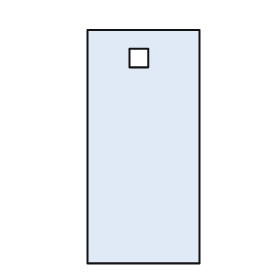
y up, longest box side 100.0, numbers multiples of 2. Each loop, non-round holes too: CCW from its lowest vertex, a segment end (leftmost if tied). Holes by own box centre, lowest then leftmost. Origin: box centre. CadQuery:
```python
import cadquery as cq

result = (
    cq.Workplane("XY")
    .moveTo(-24.0, -50.0)
    .lineTo(24.0, -50.0)
    .lineTo(24.0, 50.0)
    .lineTo(-24.0, 50.0)
    .close()
    .moveTo(-6.0, 34.0)
    .lineTo(2.0, 34.0)
    .lineTo(2.0, 42.0)
    .lineTo(-6.0, 42.0)
    .close()
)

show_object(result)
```